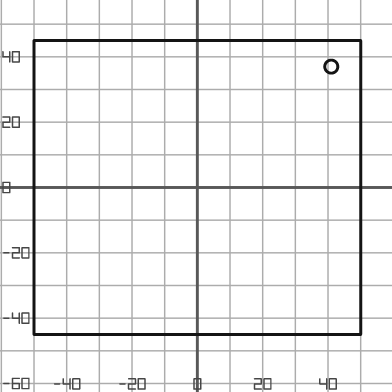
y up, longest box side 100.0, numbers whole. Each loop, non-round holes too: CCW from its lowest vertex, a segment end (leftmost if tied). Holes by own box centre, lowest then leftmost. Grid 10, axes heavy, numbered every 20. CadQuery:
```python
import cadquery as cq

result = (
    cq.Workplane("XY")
    .moveTo(-50.0, -45.0)
    .lineTo(50.0, -45.0)
    .lineTo(50.0, 45.0)
    .lineTo(-50.0, 45.0)
    .close()
    .moveTo(41.0, 37.0)
    .circle(2.0)
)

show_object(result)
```